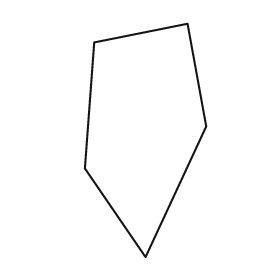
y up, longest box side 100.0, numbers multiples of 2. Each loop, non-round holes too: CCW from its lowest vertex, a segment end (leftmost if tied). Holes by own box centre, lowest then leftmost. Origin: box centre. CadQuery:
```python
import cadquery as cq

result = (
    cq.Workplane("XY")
    .moveTo(0.0, -50.0)
    .lineTo(26.0, 6.0)
    .lineTo(18.0, 50.0)
    .lineTo(-22.0, 42.0)
    .lineTo(-26.0, -12.0)
    .close()
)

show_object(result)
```